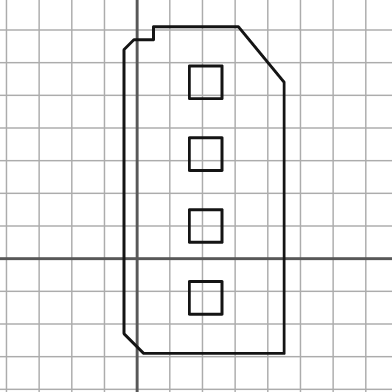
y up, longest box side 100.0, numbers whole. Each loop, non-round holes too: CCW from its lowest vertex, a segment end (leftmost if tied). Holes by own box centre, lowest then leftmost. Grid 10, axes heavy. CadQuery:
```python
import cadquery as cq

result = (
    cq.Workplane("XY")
    .moveTo(2.0, -29.0)
    .lineTo(45.0, -29.0)
    .lineTo(45.0, 54.0)
    .lineTo(31.0, 71.0)
    .lineTo(5.0, 71.0)
    .lineTo(5.0, 67.0)
    .lineTo(-1.0, 67.0)
    .lineTo(-4.0, 64.0)
    .lineTo(-4.0, -23.0)
    .close()
    .moveTo(16.0, -17.0)
    .lineTo(26.0, -17.0)
    .lineTo(26.0, -7.0)
    .lineTo(16.0, -7.0)
    .close()
    .moveTo(16.0, 5.0)
    .lineTo(26.0, 5.0)
    .lineTo(26.0, 15.0)
    .lineTo(16.0, 15.0)
    .close()
    .moveTo(16.0, 27.0)
    .lineTo(26.0, 27.0)
    .lineTo(26.0, 37.0)
    .lineTo(16.0, 37.0)
    .close()
    .moveTo(16.0, 49.0)
    .lineTo(26.0, 49.0)
    .lineTo(26.0, 59.0)
    .lineTo(16.0, 59.0)
    .close()
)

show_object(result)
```